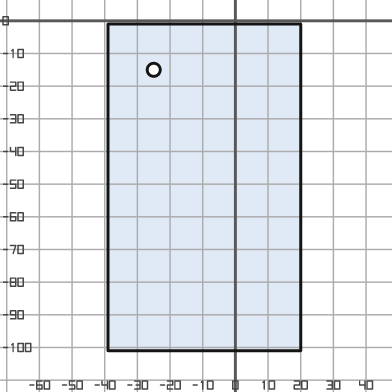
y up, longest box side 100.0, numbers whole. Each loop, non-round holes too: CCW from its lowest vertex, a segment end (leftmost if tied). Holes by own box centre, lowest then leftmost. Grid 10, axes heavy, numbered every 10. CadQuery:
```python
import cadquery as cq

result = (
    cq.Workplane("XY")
    .moveTo(-39.0, -101.0)
    .lineTo(20.0, -101.0)
    .lineTo(20.0, -1.0)
    .lineTo(-39.0, -1.0)
    .close()
    .moveTo(-25.0, -15.0)
    .circle(2.0)
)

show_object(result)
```